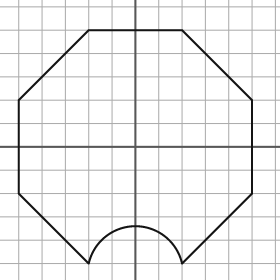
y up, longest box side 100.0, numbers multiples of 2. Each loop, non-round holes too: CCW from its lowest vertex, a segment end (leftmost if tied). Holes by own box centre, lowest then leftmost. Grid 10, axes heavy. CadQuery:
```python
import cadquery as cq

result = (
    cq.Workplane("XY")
    .moveTo(-20.0, -50.0)
    .threePointArc((0.0, -34.0), (20.0, -50.0))
    .lineTo(50.0, -20.0)
    .lineTo(50.0, 20.0)
    .lineTo(20.0, 50.0)
    .lineTo(-20.0, 50.0)
    .lineTo(-50.0, 20.0)
    .lineTo(-50.0, -20.0)
    .close()
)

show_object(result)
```